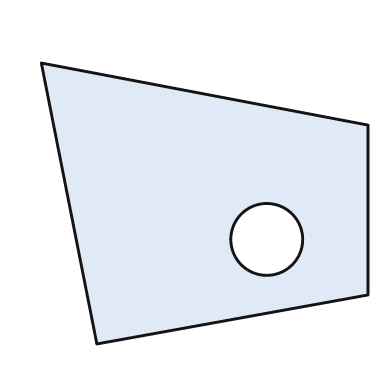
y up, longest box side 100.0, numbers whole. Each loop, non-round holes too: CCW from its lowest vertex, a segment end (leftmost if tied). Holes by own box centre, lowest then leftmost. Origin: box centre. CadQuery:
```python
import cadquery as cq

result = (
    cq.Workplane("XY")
    .moveTo(-33.0, -43.0)
    .lineTo(50.0, -28.0)
    .lineTo(50.0, 24.0)
    .lineTo(-50.0, 43.0)
    .close()
    .moveTo(19.0, -11.0)
    .circle(11.0)
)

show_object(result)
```